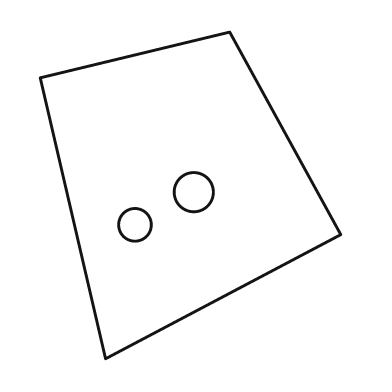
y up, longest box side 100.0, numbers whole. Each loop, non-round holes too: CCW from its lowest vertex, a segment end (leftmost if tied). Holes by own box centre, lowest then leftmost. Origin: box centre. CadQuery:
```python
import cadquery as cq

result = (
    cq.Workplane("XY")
    .moveTo(-26.0, -50.0)
    .lineTo(46.0, -12.0)
    .lineTo(12.0, 50.0)
    .lineTo(-46.0, 36.0)
    .close()
    .moveTo(-17.0, -9.0)
    .circle(5.0)
    .moveTo(1.0, 1.0)
    .circle(6.0)
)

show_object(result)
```